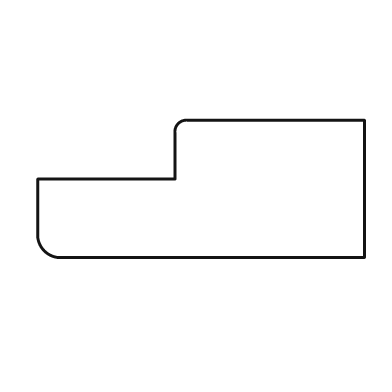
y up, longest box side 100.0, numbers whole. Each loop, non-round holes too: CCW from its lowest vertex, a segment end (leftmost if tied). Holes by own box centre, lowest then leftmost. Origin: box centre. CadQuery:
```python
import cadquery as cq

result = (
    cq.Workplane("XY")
    .moveTo(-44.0, -21.0)
    .lineTo(50.0, -21.0)
    .lineTo(50.0, 21.0)
    .lineTo(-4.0, 21.0)
    .threePointArc((-7.0, 20.0), (-8.0, 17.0))
    .lineTo(-8.0, 3.0)
    .lineTo(-50.0, 3.0)
    .lineTo(-50.0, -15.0)
    .threePointArc((-48.0, -19.0), (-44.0, -21.0))
    .close()
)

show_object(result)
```